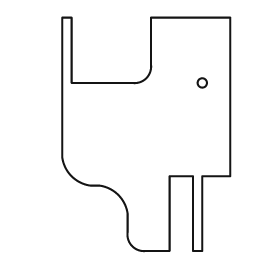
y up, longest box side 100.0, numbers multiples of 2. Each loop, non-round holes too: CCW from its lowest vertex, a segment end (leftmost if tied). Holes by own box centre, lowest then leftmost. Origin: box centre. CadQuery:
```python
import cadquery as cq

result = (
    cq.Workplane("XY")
    .moveTo(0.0, -50.0)
    .lineTo(10.0, -50.0)
    .lineTo(10.0, -18.0)
    .lineTo(20.0, -18.0)
    .lineTo(20.0, -50.0)
    .lineTo(24.0, -50.0)
    .lineTo(24.0, -18.0)
    .lineTo(36.0, -18.0)
    .lineTo(36.0, 50.0)
    .lineTo(2.0, 50.0)
    .lineTo(2.0, 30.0)
    .threePointArc((0.0, 24.0), (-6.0, 22.0))
    .lineTo(-32.0, 22.0)
    .lineTo(-32.0, 50.0)
    .lineTo(-36.0, 50.0)
    .lineTo(-36.0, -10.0)
    .threePointArc((-32.0, -18.0), (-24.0, -22.0))
    .lineTo(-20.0, -22.0)
    .threePointArc((-12.0, -26.0), (-8.0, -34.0))
    .lineTo(-8.0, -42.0)
    .threePointArc((-6.0, -48.0), (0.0, -50.0))
    .close()
    .moveTo(24.0, 22.0)
    .circle(2.0)
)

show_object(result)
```